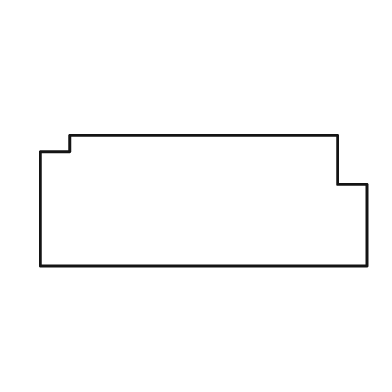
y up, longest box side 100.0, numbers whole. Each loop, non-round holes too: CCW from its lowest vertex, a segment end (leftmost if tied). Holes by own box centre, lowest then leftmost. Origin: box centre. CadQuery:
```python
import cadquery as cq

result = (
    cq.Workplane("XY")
    .moveTo(-50.0, -20.0)
    .lineTo(50.0, -20.0)
    .lineTo(50.0, 5.0)
    .lineTo(41.0, 5.0)
    .lineTo(41.0, 20.0)
    .lineTo(-41.0, 20.0)
    .lineTo(-41.0, 15.0)
    .lineTo(-50.0, 15.0)
    .close()
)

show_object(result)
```